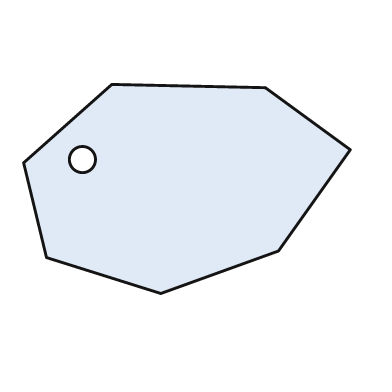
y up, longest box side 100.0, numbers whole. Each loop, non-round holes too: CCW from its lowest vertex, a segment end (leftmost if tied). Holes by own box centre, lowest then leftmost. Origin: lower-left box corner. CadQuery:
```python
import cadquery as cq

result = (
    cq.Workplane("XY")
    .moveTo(42.0, 0.0)
    .lineTo(78.0, 13.0)
    .lineTo(100.0, 44.0)
    .lineTo(74.0, 63.0)
    .lineTo(27.0, 64.0)
    .lineTo(0.0, 40.0)
    .lineTo(7.0, 11.0)
    .close()
    .moveTo(18.0, 41.0)
    .circle(4.0)
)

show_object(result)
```